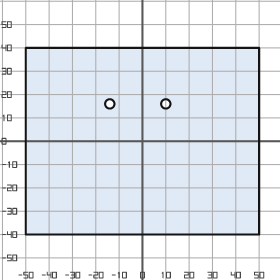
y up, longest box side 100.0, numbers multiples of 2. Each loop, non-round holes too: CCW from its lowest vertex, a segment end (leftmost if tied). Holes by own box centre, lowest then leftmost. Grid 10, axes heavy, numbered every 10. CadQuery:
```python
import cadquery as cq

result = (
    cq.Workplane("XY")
    .moveTo(-50.0, -40.0)
    .lineTo(50.0, -40.0)
    .lineTo(50.0, 40.0)
    .lineTo(-50.0, 40.0)
    .close()
    .moveTo(-14.0, 16.0)
    .circle(2.0)
    .moveTo(10.0, 16.0)
    .circle(2.0)
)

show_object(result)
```